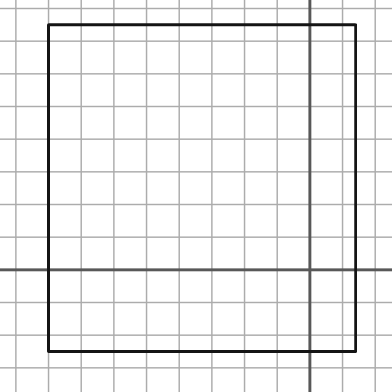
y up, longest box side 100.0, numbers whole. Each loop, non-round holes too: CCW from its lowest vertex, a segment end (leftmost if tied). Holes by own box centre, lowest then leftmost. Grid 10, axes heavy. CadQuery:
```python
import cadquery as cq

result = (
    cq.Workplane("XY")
    .moveTo(-80.0, -25.0)
    .lineTo(14.0, -25.0)
    .lineTo(14.0, 75.0)
    .lineTo(-80.0, 75.0)
    .close()
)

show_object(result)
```